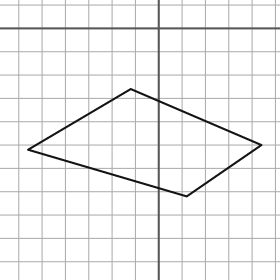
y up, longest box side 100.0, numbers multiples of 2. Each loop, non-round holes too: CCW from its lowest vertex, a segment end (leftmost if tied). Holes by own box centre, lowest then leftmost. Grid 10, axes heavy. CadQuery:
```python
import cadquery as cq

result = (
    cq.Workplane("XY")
    .moveTo(12.0, -72.0)
    .lineTo(44.0, -50.0)
    .lineTo(-12.0, -26.0)
    .lineTo(-56.0, -52.0)
    .close()
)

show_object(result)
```